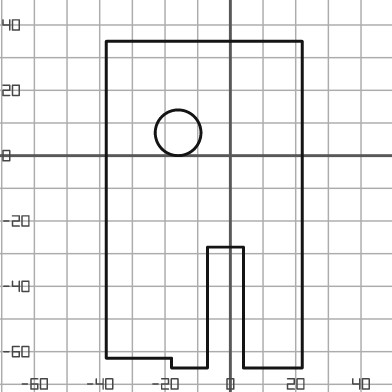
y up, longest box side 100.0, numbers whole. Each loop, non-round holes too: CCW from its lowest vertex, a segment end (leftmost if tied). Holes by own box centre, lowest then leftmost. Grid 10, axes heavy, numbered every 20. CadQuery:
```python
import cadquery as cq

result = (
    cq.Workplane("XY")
    .moveTo(-18.0, -65.0)
    .lineTo(-7.0, -65.0)
    .lineTo(-7.0, -28.0)
    .lineTo(4.0, -28.0)
    .lineTo(4.0, -65.0)
    .lineTo(22.0, -65.0)
    .lineTo(22.0, 35.0)
    .lineTo(-38.0, 35.0)
    .lineTo(-38.0, -62.0)
    .lineTo(-18.0, -62.0)
    .close()
    .moveTo(-16.0, 7.0)
    .circle(7.0)
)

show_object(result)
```